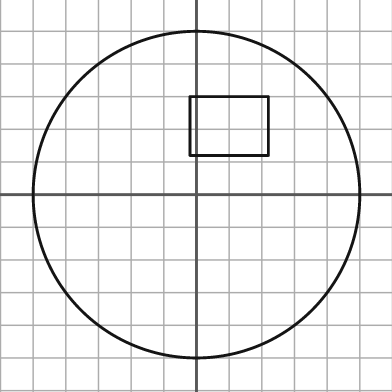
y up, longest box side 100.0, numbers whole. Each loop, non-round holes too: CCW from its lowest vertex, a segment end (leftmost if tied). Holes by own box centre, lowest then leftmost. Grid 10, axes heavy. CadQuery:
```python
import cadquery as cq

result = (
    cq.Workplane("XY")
    .moveTo(0.0, 0.0)
    .circle(50.0)
    .moveTo(-2.0, 12.0)
    .lineTo(22.0, 12.0)
    .lineTo(22.0, 30.0)
    .lineTo(-2.0, 30.0)
    .close()
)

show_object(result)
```